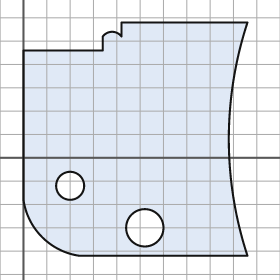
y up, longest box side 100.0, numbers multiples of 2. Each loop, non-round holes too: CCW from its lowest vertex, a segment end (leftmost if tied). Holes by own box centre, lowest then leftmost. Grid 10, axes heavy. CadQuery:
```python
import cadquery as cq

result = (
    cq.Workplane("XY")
    .moveTo(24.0, -42.0)
    .lineTo(96.0, -42.0)
    .threePointArc((88.0, 8.0), (96.0, 58.0))
    .lineTo(42.0, 58.0)
    .lineTo(42.0, 52.0)
    .threePointArc((38.0, 54.0), (34.0, 52.0))
    .lineTo(34.0, 46.0)
    .lineTo(0.0, 46.0)
    .lineTo(0.0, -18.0)
    .threePointArc((8.0, -34.0), (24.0, -42.0))
    .close()
    .moveTo(52.0, -30.0)
    .circle(8.0)
    .moveTo(20.0, -12.0)
    .circle(6.0)
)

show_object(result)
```